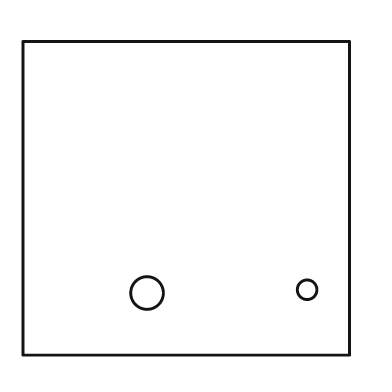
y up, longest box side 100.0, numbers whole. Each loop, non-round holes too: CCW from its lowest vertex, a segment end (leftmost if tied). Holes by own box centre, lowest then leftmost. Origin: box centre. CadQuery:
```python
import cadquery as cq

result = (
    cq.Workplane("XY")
    .moveTo(-50.0, -48.0)
    .lineTo(50.0, -48.0)
    .lineTo(50.0, 48.0)
    .lineTo(-50.0, 48.0)
    .close()
    .moveTo(-12.0, -29.0)
    .circle(5.0)
    .moveTo(37.0, -28.0)
    .circle(3.0)
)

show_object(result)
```